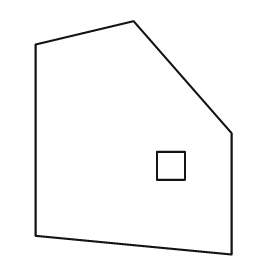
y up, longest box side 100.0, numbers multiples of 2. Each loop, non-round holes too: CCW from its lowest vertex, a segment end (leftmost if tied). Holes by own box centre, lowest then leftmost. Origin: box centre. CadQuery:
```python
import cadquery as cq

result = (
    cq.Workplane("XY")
    .moveTo(42.0, -50.0)
    .lineTo(42.0, 2.0)
    .lineTo(0.0, 50.0)
    .lineTo(-42.0, 40.0)
    .lineTo(-42.0, -42.0)
    .close()
    .moveTo(10.0, -18.0)
    .lineTo(22.0, -18.0)
    .lineTo(22.0, -6.0)
    .lineTo(10.0, -6.0)
    .close()
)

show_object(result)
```